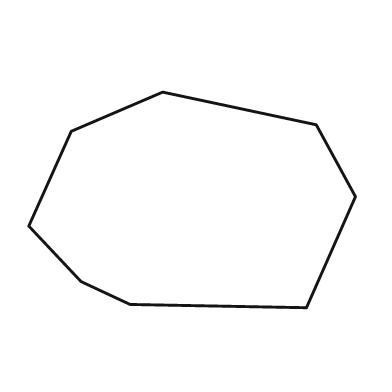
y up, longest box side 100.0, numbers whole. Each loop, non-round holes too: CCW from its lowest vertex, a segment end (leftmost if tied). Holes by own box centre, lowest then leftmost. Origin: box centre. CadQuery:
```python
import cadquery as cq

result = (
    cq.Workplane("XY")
    .moveTo(35.0, -33.0)
    .lineTo(50.0, 1.0)
    .lineTo(38.0, 23.0)
    .lineTo(-9.0, 33.0)
    .lineTo(-37.0, 21.0)
    .lineTo(-50.0, -8.0)
    .lineTo(-34.0, -25.0)
    .lineTo(-19.0, -32.0)
    .close()
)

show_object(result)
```